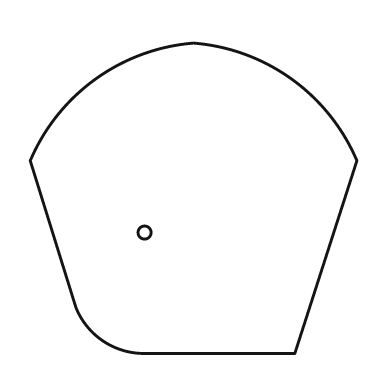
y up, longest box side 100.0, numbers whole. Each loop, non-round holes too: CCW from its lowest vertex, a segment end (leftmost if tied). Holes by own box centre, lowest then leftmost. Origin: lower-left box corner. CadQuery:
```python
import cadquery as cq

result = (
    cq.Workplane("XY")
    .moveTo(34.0, 0.0)
    .lineTo(81.0, 0.0)
    .lineTo(100.0, 59.0)
    .threePointArc((80.0, 84.0), (50.0, 95.0))
    .threePointArc((20.0, 84.0), (0.0, 59.0))
    .lineTo(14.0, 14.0)
    .threePointArc((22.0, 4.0), (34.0, 0.0))
    .close()
    .moveTo(35.0, 37.0)
    .circle(2.0)
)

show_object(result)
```